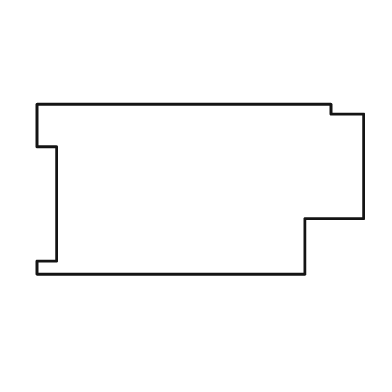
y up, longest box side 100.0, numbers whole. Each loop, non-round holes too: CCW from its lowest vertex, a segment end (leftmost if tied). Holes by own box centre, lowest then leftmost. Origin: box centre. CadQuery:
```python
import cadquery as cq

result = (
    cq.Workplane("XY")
    .moveTo(-50.0, -26.0)
    .lineTo(32.0, -26.0)
    .lineTo(32.0, -9.0)
    .lineTo(50.0, -9.0)
    .lineTo(50.0, 23.0)
    .lineTo(40.0, 23.0)
    .lineTo(40.0, 26.0)
    .lineTo(-50.0, 26.0)
    .lineTo(-50.0, 13.0)
    .lineTo(-44.0, 13.0)
    .lineTo(-44.0, -22.0)
    .lineTo(-50.0, -22.0)
    .close()
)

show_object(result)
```